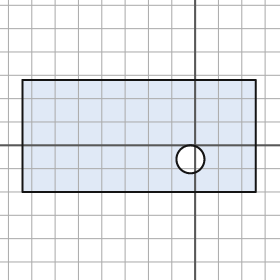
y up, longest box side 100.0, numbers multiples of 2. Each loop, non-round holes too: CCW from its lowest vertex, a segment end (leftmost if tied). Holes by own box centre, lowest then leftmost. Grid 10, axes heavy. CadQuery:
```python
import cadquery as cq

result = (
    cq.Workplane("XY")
    .moveTo(-74.0, -20.0)
    .lineTo(26.0, -20.0)
    .lineTo(26.0, 28.0)
    .lineTo(-74.0, 28.0)
    .close()
    .moveTo(-2.0, -6.0)
    .circle(6.0)
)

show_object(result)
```